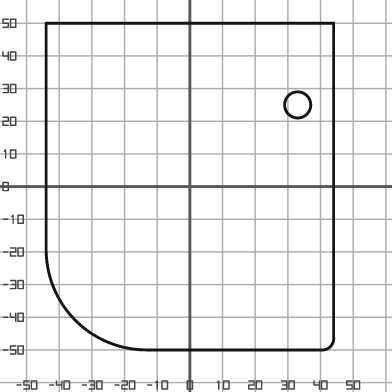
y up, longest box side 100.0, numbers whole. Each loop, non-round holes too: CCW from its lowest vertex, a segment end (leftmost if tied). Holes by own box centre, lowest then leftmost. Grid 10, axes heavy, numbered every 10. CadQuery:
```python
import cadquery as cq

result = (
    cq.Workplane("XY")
    .moveTo(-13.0, -50.0)
    .lineTo(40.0, -50.0)
    .threePointArc((43.0, -49.0), (44.0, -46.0))
    .lineTo(44.0, 50.0)
    .lineTo(-44.0, 50.0)
    .lineTo(-44.0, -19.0)
    .threePointArc((-35.0, -41.0), (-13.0, -50.0))
    .close()
    .moveTo(33.0, 25.0)
    .circle(4.0)
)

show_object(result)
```